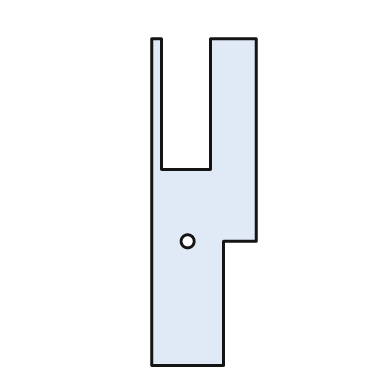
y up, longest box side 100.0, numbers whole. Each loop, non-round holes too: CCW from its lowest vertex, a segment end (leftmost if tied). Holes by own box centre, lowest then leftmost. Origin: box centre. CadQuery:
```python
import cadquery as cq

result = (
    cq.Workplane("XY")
    .moveTo(-16.0, -50.0)
    .lineTo(6.0, -50.0)
    .lineTo(6.0, -12.0)
    .lineTo(16.0, -12.0)
    .lineTo(16.0, 50.0)
    .lineTo(2.0, 50.0)
    .lineTo(2.0, 10.0)
    .lineTo(-13.0, 10.0)
    .lineTo(-13.0, 50.0)
    .lineTo(-16.0, 50.0)
    .close()
    .moveTo(-5.0, -12.0)
    .circle(2.0)
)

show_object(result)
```